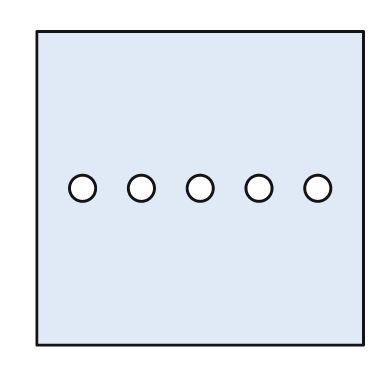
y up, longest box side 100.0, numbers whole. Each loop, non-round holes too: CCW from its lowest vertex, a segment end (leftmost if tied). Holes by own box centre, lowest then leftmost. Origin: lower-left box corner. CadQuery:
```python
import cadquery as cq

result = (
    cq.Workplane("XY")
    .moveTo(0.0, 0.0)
    .lineTo(100.0, 0.0)
    .lineTo(100.0, 96.0)
    .lineTo(0.0, 96.0)
    .close()
    .moveTo(14.0, 48.0)
    .circle(4.0)
    .moveTo(32.0, 48.0)
    .circle(4.0)
    .moveTo(50.0, 48.0)
    .circle(4.0)
    .moveTo(68.0, 48.0)
    .circle(4.0)
    .moveTo(86.0, 48.0)
    .circle(4.0)
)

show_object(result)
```